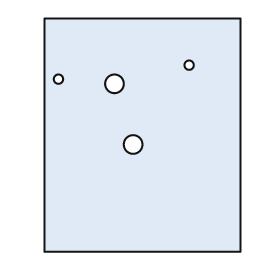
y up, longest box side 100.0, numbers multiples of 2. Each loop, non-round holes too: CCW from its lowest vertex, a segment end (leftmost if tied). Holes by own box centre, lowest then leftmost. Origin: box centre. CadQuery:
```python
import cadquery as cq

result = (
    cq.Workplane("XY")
    .moveTo(-42.0, -50.0)
    .lineTo(42.0, -50.0)
    .lineTo(42.0, 50.0)
    .lineTo(-42.0, 50.0)
    .close()
    .moveTo(-4.0, -4.0)
    .circle(4.0)
    .moveTo(-12.0, 22.0)
    .circle(4.0)
    .moveTo(-36.0, 24.0)
    .circle(2.0)
    .moveTo(20.0, 30.0)
    .circle(2.0)
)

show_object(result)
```